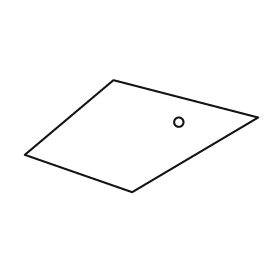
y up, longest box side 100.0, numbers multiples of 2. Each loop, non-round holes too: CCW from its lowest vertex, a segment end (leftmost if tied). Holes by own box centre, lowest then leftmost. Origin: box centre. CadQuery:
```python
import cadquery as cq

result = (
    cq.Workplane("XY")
    .moveTo(-4.0, -24.0)
    .lineTo(50.0, 8.0)
    .lineTo(-12.0, 24.0)
    .lineTo(-50.0, -8.0)
    .close()
    .moveTo(16.0, 6.0)
    .circle(2.0)
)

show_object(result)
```